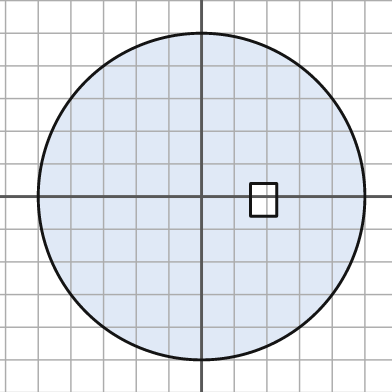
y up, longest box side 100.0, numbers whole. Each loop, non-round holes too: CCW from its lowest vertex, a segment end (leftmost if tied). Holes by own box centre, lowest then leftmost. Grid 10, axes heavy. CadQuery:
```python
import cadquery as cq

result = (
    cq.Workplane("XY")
    .moveTo(0.0, 0.0)
    .circle(50.0)
    .moveTo(15.0, -6.0)
    .lineTo(23.0, -6.0)
    .lineTo(23.0, 4.0)
    .lineTo(15.0, 4.0)
    .close()
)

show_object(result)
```